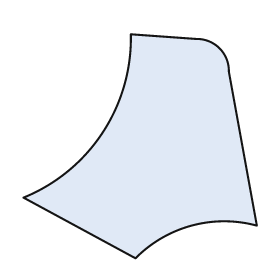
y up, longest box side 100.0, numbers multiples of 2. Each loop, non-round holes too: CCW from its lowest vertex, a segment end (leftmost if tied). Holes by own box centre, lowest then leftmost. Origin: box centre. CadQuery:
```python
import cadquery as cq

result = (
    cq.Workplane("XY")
    .moveTo(-2.0, -48.0)
    .threePointArc((22.0, -34.0), (50.0, -34.0))
    .lineTo(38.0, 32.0)
    .threePointArc((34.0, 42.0), (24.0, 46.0))
    .lineTo(-4.0, 48.0)
    .threePointArc((-16.0, 6.0), (-50.0, -22.0))
    .close()
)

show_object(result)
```